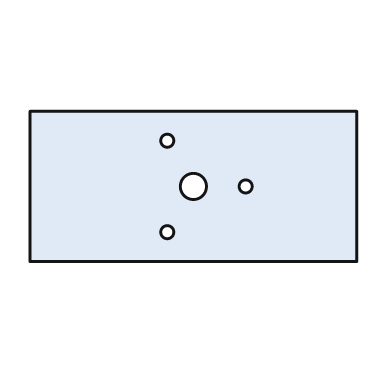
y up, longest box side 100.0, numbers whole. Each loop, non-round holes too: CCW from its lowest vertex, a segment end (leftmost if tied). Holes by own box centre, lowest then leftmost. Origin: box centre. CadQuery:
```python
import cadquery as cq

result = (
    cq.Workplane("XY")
    .moveTo(-50.0, -23.0)
    .lineTo(50.0, -23.0)
    .lineTo(50.0, 23.0)
    .lineTo(-50.0, 23.0)
    .close()
    .moveTo(-8.0, -14.0)
    .circle(2.0)
    .moveTo(0.0, 0.0)
    .circle(4.0)
    .moveTo(16.0, 0.0)
    .circle(2.0)
    .moveTo(-8.0, 14.0)
    .circle(2.0)
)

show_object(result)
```